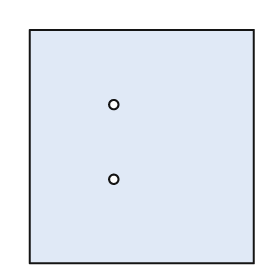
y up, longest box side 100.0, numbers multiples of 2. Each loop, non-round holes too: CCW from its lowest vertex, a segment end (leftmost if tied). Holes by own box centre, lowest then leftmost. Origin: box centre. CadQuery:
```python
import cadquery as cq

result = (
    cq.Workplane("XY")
    .moveTo(-48.0, -50.0)
    .lineTo(48.0, -50.0)
    .lineTo(48.0, 50.0)
    .lineTo(-48.0, 50.0)
    .close()
    .moveTo(-12.0, -14.0)
    .circle(2.0)
    .moveTo(-12.0, 18.0)
    .circle(2.0)
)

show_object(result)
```